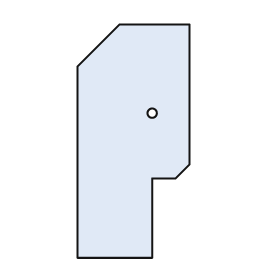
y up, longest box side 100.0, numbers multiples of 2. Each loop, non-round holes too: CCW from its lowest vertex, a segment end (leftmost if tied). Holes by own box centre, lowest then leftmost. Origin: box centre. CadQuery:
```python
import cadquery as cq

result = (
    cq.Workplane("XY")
    .moveTo(-24.0, -50.0)
    .lineTo(8.0, -50.0)
    .lineTo(8.0, -16.0)
    .lineTo(18.0, -16.0)
    .lineTo(24.0, -10.0)
    .lineTo(24.0, 50.0)
    .lineTo(-6.0, 50.0)
    .lineTo(-24.0, 32.0)
    .close()
    .moveTo(8.0, 12.0)
    .circle(2.0)
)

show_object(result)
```